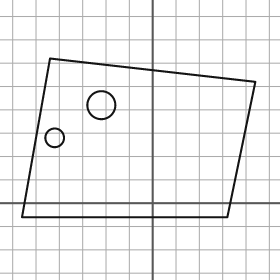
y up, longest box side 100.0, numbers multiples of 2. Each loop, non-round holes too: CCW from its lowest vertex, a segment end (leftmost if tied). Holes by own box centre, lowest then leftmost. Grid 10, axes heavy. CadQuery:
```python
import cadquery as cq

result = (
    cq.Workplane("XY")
    .moveTo(-56.0, -6.0)
    .lineTo(32.0, -6.0)
    .lineTo(44.0, 52.0)
    .lineTo(-44.0, 62.0)
    .close()
    .moveTo(-42.0, 28.0)
    .circle(4.0)
    .moveTo(-22.0, 42.0)
    .circle(6.0)
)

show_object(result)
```